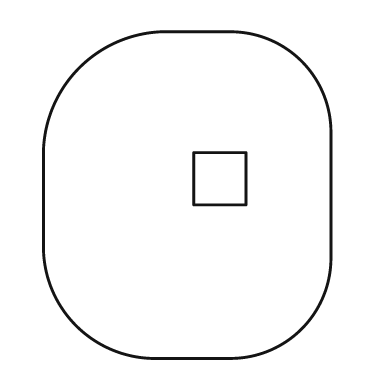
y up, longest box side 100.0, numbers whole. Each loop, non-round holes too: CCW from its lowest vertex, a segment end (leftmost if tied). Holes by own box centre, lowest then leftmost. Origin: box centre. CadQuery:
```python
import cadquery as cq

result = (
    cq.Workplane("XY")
    .moveTo(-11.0, -50.0)
    .lineTo(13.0, -50.0)
    .threePointArc((35.0, -41.0), (44.0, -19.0))
    .lineTo(44.0, 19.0)
    .threePointArc((35.0, 41.0), (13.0, 50.0))
    .lineTo(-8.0, 50.0)
    .threePointArc((-33.0, 39.0), (-44.0, 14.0))
    .lineTo(-44.0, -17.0)
    .threePointArc((-34.0, -40.0), (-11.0, -50.0))
    .close()
    .moveTo(2.0, -3.0)
    .lineTo(18.0, -3.0)
    .lineTo(18.0, 13.0)
    .lineTo(2.0, 13.0)
    .close()
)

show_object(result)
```